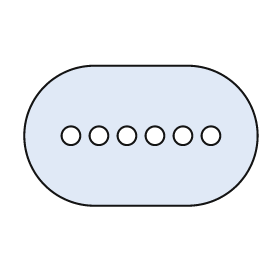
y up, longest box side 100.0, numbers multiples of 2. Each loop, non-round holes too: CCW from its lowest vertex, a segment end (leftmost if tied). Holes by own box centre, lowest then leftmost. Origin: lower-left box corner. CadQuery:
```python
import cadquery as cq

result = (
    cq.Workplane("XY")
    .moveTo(30.0, 0.0)
    .lineTo(70.0, 0.0)
    .threePointArc((100.0, 30.0), (70.0, 60.0))
    .lineTo(30.0, 60.0)
    .threePointArc((0.0, 30.0), (30.0, 0.0))
    .close()
    .moveTo(20.0, 30.0)
    .circle(4.0)
    .moveTo(32.0, 30.0)
    .circle(4.0)
    .moveTo(44.0, 30.0)
    .circle(4.0)
    .moveTo(56.0, 30.0)
    .circle(4.0)
    .moveTo(68.0, 30.0)
    .circle(4.0)
    .moveTo(80.0, 30.0)
    .circle(4.0)
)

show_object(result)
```